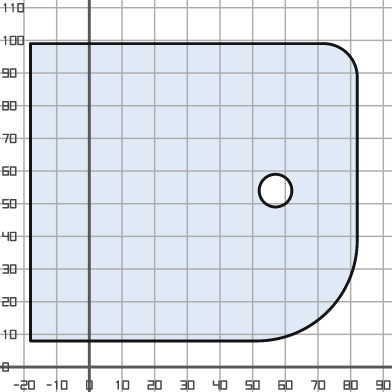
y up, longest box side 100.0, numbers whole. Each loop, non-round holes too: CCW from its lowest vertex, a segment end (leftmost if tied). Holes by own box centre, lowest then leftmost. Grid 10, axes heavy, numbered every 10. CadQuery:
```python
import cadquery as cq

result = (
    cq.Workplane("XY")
    .moveTo(-18.0, 8.0)
    .lineTo(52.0, 8.0)
    .threePointArc((73.0, 17.0), (82.0, 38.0))
    .lineTo(82.0, 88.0)
    .threePointArc((79.0, 96.0), (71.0, 99.0))
    .lineTo(-18.0, 99.0)
    .close()
    .moveTo(57.0, 54.0)
    .circle(5.0)
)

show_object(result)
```